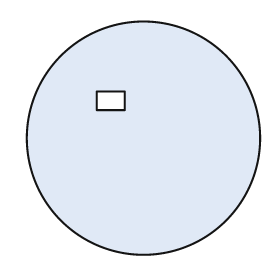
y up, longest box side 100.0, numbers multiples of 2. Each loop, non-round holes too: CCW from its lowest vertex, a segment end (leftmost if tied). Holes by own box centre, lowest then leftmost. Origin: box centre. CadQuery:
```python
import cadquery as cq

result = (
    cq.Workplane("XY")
    .moveTo(0.0, 0.0)
    .circle(50.0)
    .moveTo(-20.0, 12.0)
    .lineTo(-8.0, 12.0)
    .lineTo(-8.0, 20.0)
    .lineTo(-20.0, 20.0)
    .close()
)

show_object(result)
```